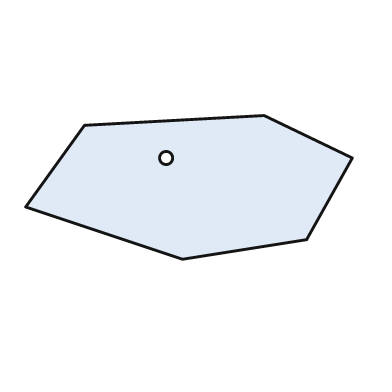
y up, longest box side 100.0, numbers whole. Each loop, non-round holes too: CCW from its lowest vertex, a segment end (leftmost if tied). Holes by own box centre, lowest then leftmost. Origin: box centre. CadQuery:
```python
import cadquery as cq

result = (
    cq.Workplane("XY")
    .moveTo(-2.0, -22.0)
    .lineTo(36.0, -16.0)
    .lineTo(50.0, 9.0)
    .lineTo(23.0, 22.0)
    .lineTo(-32.0, 19.0)
    .lineTo(-50.0, -6.0)
    .close()
    .moveTo(-7.0, 9.0)
    .circle(2.0)
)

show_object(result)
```